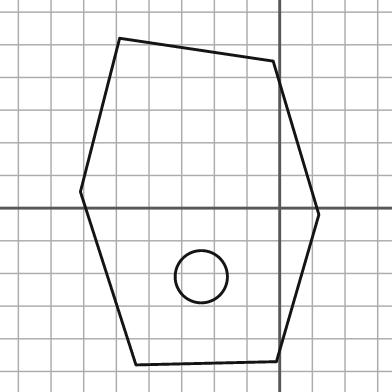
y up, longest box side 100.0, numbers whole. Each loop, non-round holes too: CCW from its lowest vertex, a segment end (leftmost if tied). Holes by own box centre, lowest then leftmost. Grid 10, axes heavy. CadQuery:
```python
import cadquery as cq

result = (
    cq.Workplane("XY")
    .moveTo(-44.0, -48.0)
    .lineTo(-1.0, -47.0)
    .lineTo(12.0, -2.0)
    .lineTo(-2.0, 45.0)
    .lineTo(-49.0, 52.0)
    .lineTo(-61.0, 5.0)
    .close()
    .moveTo(-24.0, -21.0)
    .circle(8.0)
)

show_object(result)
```